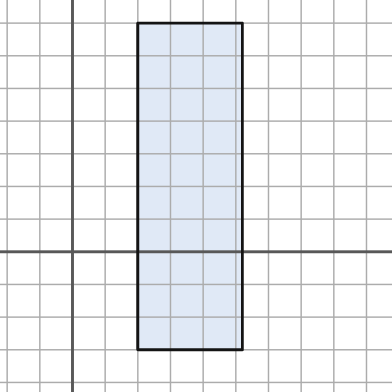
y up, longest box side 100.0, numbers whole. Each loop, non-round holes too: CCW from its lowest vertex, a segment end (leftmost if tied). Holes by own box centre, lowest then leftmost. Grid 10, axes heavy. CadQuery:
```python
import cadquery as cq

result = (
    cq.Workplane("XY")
    .moveTo(20.0, -30.0)
    .lineTo(52.0, -30.0)
    .lineTo(52.0, 70.0)
    .lineTo(20.0, 70.0)
    .close()
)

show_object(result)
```